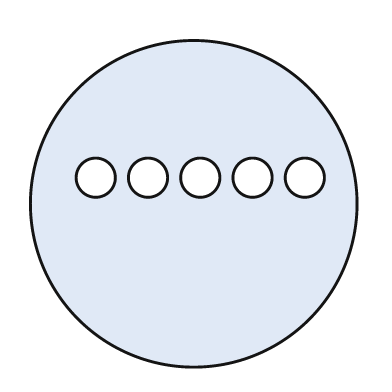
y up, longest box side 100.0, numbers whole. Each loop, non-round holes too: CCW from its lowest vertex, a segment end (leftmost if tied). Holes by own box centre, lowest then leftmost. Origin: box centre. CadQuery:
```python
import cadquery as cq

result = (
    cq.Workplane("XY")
    .moveTo(0.0, 0.0)
    .circle(50.0)
    .moveTo(-30.0, 8.0)
    .circle(6.0)
    .moveTo(-14.0, 8.0)
    .circle(6.0)
    .moveTo(2.0, 8.0)
    .circle(6.0)
    .moveTo(18.0, 8.0)
    .circle(6.0)
    .moveTo(34.0, 8.0)
    .circle(6.0)
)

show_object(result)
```